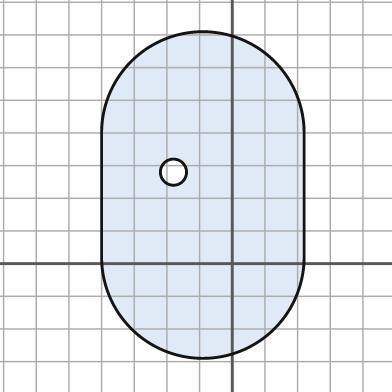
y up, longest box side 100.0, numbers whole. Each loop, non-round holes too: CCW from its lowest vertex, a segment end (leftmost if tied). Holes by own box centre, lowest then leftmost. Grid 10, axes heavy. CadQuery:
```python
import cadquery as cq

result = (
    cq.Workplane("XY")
    .moveTo(-40.0, 2.0)
    .threePointArc((-9.0, -29.0), (22.0, 2.0))
    .lineTo(22.0, 40.0)
    .threePointArc((-9.0, 71.0), (-40.0, 40.0))
    .close()
    .moveTo(-18.0, 28.0)
    .circle(4.0)
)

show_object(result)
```